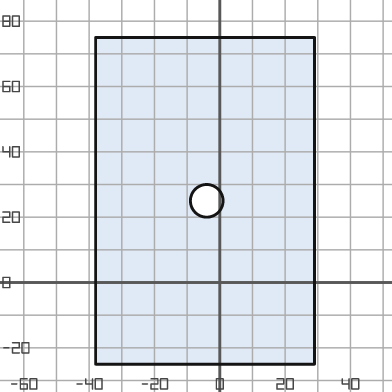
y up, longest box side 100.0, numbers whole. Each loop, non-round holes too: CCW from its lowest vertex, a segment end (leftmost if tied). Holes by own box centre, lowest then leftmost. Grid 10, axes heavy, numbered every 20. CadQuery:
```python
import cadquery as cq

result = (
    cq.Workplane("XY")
    .moveTo(-38.0, -25.0)
    .lineTo(29.0, -25.0)
    .lineTo(29.0, 75.0)
    .lineTo(-38.0, 75.0)
    .close()
    .moveTo(-4.0, 25.0)
    .circle(5.0)
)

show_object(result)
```